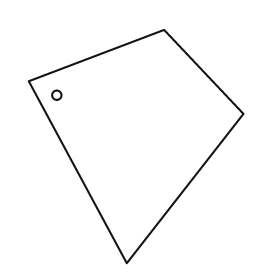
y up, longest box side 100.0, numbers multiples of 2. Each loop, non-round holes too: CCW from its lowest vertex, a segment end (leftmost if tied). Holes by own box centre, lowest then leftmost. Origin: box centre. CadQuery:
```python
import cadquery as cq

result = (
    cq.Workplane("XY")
    .moveTo(-4.0, -50.0)
    .lineTo(46.0, 14.0)
    .lineTo(12.0, 50.0)
    .lineTo(-46.0, 28.0)
    .close()
    .moveTo(-34.0, 22.0)
    .circle(2.0)
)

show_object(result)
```